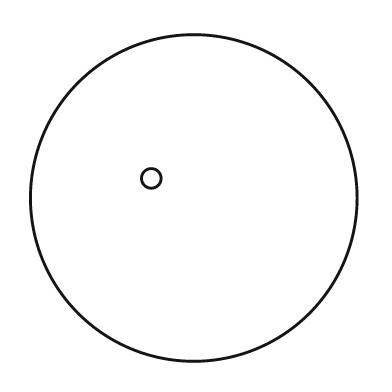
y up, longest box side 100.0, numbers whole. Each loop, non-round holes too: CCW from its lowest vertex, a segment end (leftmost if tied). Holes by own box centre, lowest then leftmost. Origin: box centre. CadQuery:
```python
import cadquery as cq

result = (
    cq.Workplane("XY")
    .moveTo(0.0, 0.0)
    .circle(50.0)
    .moveTo(-13.0, 6.0)
    .circle(3.0)
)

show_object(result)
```